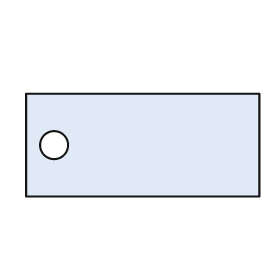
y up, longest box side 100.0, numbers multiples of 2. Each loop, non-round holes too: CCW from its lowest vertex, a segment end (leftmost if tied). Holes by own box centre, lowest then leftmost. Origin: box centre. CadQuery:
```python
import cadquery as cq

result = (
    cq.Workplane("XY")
    .moveTo(-50.0, -22.0)
    .lineTo(50.0, -22.0)
    .lineTo(50.0, 22.0)
    .lineTo(-50.0, 22.0)
    .close()
    .moveTo(-38.0, 0.0)
    .circle(6.0)
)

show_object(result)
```